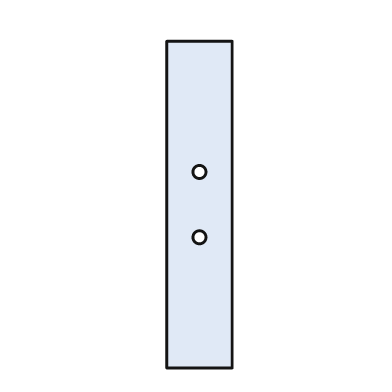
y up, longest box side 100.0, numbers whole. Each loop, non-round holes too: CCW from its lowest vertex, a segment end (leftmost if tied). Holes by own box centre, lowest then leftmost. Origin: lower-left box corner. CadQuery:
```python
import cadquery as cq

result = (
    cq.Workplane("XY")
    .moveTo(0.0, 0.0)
    .lineTo(20.0, 0.0)
    .lineTo(20.0, 100.0)
    .lineTo(0.0, 100.0)
    .close()
    .moveTo(10.0, 40.0)
    .circle(2.0)
    .moveTo(10.0, 60.0)
    .circle(2.0)
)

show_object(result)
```